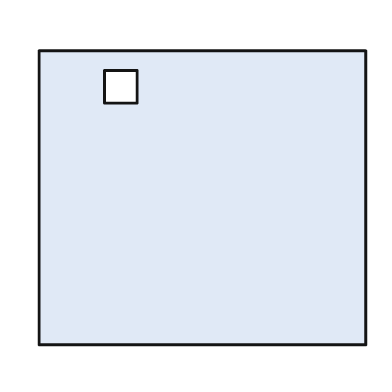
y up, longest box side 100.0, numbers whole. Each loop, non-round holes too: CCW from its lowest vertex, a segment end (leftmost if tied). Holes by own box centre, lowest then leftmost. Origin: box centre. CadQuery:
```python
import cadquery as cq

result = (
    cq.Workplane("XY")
    .moveTo(-50.0, -45.0)
    .lineTo(50.0, -45.0)
    .lineTo(50.0, 45.0)
    .lineTo(-50.0, 45.0)
    .close()
    .moveTo(-30.0, 29.0)
    .lineTo(-20.0, 29.0)
    .lineTo(-20.0, 39.0)
    .lineTo(-30.0, 39.0)
    .close()
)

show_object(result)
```